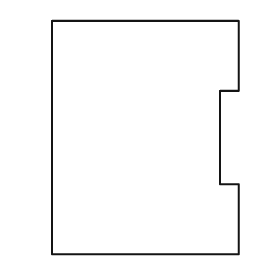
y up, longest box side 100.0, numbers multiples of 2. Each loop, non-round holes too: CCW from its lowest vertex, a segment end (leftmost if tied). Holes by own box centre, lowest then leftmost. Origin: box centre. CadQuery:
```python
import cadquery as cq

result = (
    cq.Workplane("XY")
    .moveTo(-40.0, -50.0)
    .lineTo(40.0, -50.0)
    .lineTo(40.0, -20.0)
    .lineTo(32.0, -20.0)
    .lineTo(32.0, 20.0)
    .lineTo(40.0, 20.0)
    .lineTo(40.0, 50.0)
    .lineTo(-40.0, 50.0)
    .close()
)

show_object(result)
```